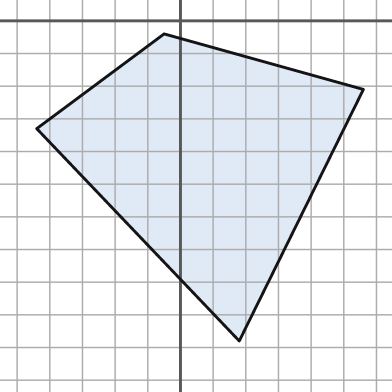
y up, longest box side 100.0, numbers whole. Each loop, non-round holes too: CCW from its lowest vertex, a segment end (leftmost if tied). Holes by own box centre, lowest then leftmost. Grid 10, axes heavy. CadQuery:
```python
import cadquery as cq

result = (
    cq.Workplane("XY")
    .moveTo(18.0, -98.0)
    .lineTo(56.0, -21.0)
    .lineTo(-5.0, -4.0)
    .lineTo(-44.0, -33.0)
    .close()
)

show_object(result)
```